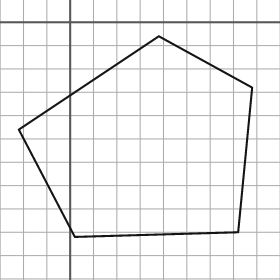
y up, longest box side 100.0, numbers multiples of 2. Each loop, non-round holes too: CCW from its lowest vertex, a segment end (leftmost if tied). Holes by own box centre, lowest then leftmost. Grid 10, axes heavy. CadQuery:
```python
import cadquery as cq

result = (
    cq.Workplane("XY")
    .moveTo(2.0, -92.0)
    .lineTo(72.0, -90.0)
    .lineTo(78.0, -28.0)
    .lineTo(38.0, -6.0)
    .lineTo(-22.0, -46.0)
    .close()
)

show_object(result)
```